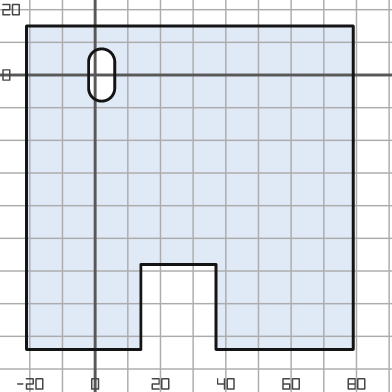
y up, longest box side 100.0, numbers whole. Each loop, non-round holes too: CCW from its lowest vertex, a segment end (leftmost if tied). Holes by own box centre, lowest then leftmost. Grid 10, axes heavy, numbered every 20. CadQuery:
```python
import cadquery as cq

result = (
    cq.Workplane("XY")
    .moveTo(-21.0, -84.0)
    .lineTo(14.0, -84.0)
    .lineTo(14.0, -58.0)
    .lineTo(37.0, -58.0)
    .lineTo(37.0, -84.0)
    .lineTo(79.0, -84.0)
    .lineTo(79.0, 15.0)
    .lineTo(-21.0, 15.0)
    .close()
    .moveTo(-2.0, -4.0)
    .threePointArc((2.0, -8.0), (6.0, -4.0))
    .lineTo(6.0, 4.0)
    .threePointArc((2.0, 8.0), (-2.0, 4.0))
    .close()
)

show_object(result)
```